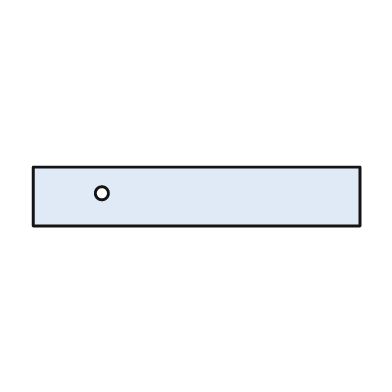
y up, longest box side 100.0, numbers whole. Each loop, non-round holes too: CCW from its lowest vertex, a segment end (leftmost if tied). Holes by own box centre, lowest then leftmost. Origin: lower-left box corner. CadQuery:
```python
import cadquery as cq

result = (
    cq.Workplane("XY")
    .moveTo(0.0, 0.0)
    .lineTo(100.0, 0.0)
    .lineTo(100.0, 18.0)
    .lineTo(0.0, 18.0)
    .close()
    .moveTo(21.0, 10.0)
    .circle(2.0)
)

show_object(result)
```